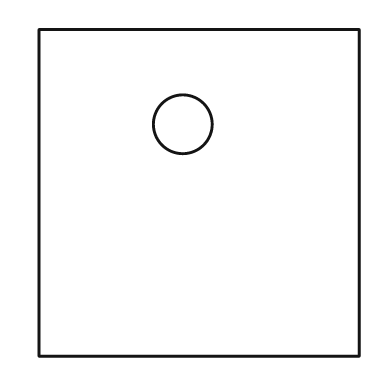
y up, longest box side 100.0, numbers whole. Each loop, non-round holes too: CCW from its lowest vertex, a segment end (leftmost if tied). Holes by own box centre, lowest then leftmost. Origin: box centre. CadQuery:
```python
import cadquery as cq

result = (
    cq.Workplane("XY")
    .moveTo(-49.0, -50.0)
    .lineTo(49.0, -50.0)
    .lineTo(49.0, 50.0)
    .lineTo(-49.0, 50.0)
    .close()
    .moveTo(-5.0, 21.0)
    .circle(9.0)
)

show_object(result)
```